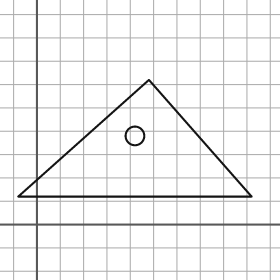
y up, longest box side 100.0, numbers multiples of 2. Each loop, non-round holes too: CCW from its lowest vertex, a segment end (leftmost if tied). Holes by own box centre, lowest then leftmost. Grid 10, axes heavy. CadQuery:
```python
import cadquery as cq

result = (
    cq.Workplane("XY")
    .moveTo(-8.0, 12.0)
    .lineTo(92.0, 12.0)
    .lineTo(48.0, 62.0)
    .close()
    .moveTo(42.0, 38.0)
    .circle(4.0)
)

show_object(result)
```